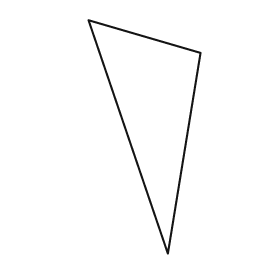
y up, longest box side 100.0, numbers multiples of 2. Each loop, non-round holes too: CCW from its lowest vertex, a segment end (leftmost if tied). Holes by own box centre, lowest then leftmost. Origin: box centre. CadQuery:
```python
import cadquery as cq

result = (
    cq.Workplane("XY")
    .moveTo(10.0, -50.0)
    .lineTo(24.0, 36.0)
    .lineTo(-24.0, 50.0)
    .close()
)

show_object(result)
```